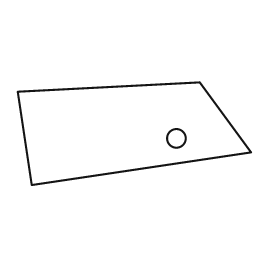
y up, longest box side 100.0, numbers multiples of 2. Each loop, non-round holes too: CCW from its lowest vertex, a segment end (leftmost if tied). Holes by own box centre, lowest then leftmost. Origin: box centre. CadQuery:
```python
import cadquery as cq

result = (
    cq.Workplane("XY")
    .moveTo(-44.0, -22.0)
    .lineTo(50.0, -8.0)
    .lineTo(28.0, 22.0)
    .lineTo(-50.0, 18.0)
    .close()
    .moveTo(18.0, -2.0)
    .circle(4.0)
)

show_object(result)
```